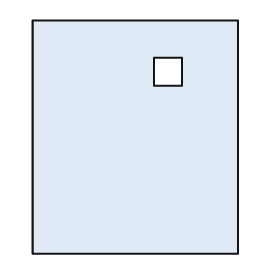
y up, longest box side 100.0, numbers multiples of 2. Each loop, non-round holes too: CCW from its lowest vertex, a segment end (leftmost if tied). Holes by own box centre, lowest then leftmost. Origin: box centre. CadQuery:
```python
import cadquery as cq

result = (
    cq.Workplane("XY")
    .moveTo(-44.0, -50.0)
    .lineTo(44.0, -50.0)
    .lineTo(44.0, 50.0)
    .lineTo(-44.0, 50.0)
    .close()
    .moveTo(8.0, 22.0)
    .lineTo(20.0, 22.0)
    .lineTo(20.0, 34.0)
    .lineTo(8.0, 34.0)
    .close()
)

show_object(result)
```